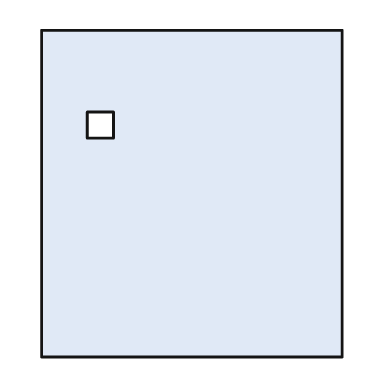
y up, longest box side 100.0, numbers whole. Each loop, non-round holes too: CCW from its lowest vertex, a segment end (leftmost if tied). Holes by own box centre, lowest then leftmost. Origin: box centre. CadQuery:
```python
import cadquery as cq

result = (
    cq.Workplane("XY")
    .moveTo(-46.0, -50.0)
    .lineTo(46.0, -50.0)
    .lineTo(46.0, 50.0)
    .lineTo(-46.0, 50.0)
    .close()
    .moveTo(-32.0, 17.0)
    .lineTo(-24.0, 17.0)
    .lineTo(-24.0, 25.0)
    .lineTo(-32.0, 25.0)
    .close()
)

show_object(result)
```